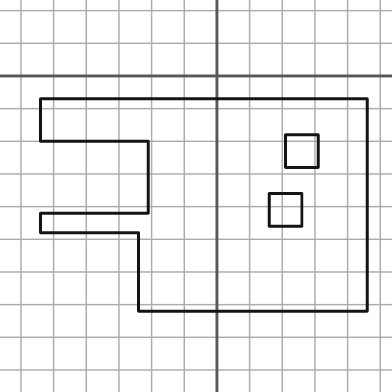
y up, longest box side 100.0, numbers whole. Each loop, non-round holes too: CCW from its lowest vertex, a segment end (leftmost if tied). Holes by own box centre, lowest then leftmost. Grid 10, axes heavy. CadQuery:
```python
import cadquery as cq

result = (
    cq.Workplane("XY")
    .moveTo(-24.0, -72.0)
    .lineTo(46.0, -72.0)
    .lineTo(46.0, -7.0)
    .lineTo(-54.0, -7.0)
    .lineTo(-54.0, -20.0)
    .lineTo(-21.0, -20.0)
    .lineTo(-21.0, -42.0)
    .lineTo(-54.0, -42.0)
    .lineTo(-54.0, -48.0)
    .lineTo(-24.0, -48.0)
    .close()
    .moveTo(16.0, -46.0)
    .lineTo(26.0, -46.0)
    .lineTo(26.0, -36.0)
    .lineTo(16.0, -36.0)
    .close()
    .moveTo(21.0, -28.0)
    .lineTo(31.0, -28.0)
    .lineTo(31.0, -18.0)
    .lineTo(21.0, -18.0)
    .close()
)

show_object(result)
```